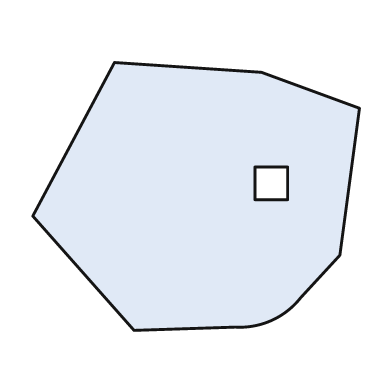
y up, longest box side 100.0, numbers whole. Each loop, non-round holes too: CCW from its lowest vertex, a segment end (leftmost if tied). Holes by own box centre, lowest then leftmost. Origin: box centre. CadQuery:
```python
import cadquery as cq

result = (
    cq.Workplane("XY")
    .moveTo(-19.0, -41.0)
    .lineTo(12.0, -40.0)
    .threePointArc((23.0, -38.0), (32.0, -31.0))
    .lineTo(44.0, -18.0)
    .lineTo(50.0, 27.0)
    .lineTo(20.0, 38.0)
    .lineTo(-25.0, 41.0)
    .lineTo(-50.0, -6.0)
    .close()
    .moveTo(18.0, -1.0)
    .lineTo(28.0, -1.0)
    .lineTo(28.0, 9.0)
    .lineTo(18.0, 9.0)
    .close()
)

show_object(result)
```